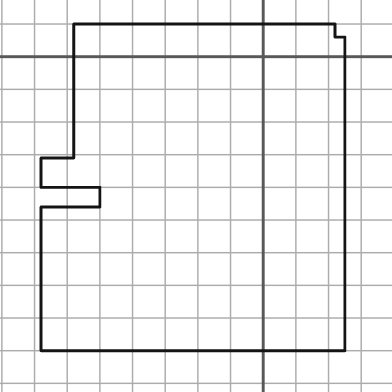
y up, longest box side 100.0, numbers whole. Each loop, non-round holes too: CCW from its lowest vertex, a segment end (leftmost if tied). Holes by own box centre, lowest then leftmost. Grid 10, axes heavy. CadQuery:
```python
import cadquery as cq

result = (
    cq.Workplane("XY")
    .moveTo(-68.0, -90.0)
    .lineTo(25.0, -90.0)
    .lineTo(25.0, 6.0)
    .lineTo(22.0, 6.0)
    .lineTo(22.0, 10.0)
    .lineTo(-58.0, 10.0)
    .lineTo(-58.0, -31.0)
    .lineTo(-68.0, -31.0)
    .lineTo(-68.0, -40.0)
    .lineTo(-50.0, -40.0)
    .lineTo(-50.0, -46.0)
    .lineTo(-68.0, -46.0)
    .close()
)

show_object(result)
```